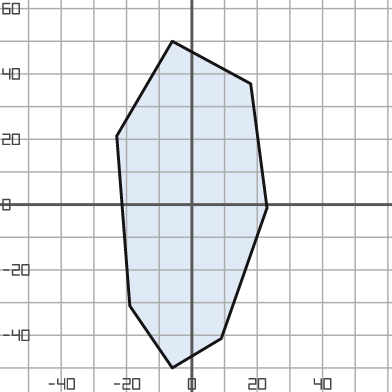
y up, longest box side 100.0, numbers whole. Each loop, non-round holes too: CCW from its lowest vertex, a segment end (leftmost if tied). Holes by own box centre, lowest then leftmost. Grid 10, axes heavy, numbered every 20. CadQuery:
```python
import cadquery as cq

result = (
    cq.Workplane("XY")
    .moveTo(-6.0, -50.0)
    .lineTo(9.0, -41.0)
    .lineTo(23.0, -1.0)
    .lineTo(18.0, 37.0)
    .lineTo(-6.0, 50.0)
    .lineTo(-23.0, 21.0)
    .lineTo(-19.0, -31.0)
    .close()
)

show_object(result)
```